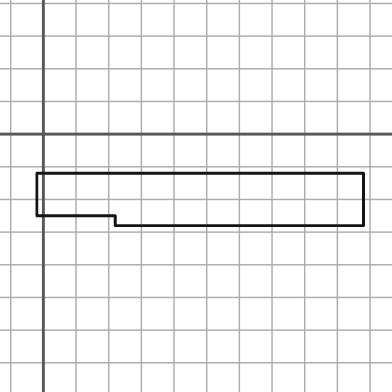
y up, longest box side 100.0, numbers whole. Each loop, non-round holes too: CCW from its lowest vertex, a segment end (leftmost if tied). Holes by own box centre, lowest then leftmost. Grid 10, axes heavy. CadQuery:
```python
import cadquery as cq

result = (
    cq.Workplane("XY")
    .moveTo(22.0, -28.0)
    .lineTo(98.0, -28.0)
    .lineTo(98.0, -12.0)
    .lineTo(-2.0, -12.0)
    .lineTo(-2.0, -25.0)
    .lineTo(22.0, -25.0)
    .close()
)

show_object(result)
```